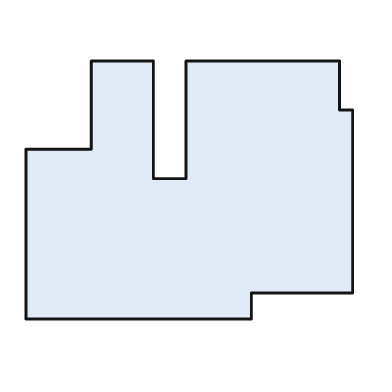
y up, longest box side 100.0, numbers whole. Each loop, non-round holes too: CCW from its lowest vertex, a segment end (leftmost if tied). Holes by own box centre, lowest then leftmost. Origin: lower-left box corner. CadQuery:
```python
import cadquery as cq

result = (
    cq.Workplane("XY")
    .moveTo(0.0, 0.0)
    .lineTo(69.0, 0.0)
    .lineTo(69.0, 8.0)
    .lineTo(100.0, 8.0)
    .lineTo(100.0, 64.0)
    .lineTo(96.0, 64.0)
    .lineTo(96.0, 79.0)
    .lineTo(49.0, 79.0)
    .lineTo(49.0, 43.0)
    .lineTo(39.0, 43.0)
    .lineTo(39.0, 79.0)
    .lineTo(20.0, 79.0)
    .lineTo(20.0, 52.0)
    .lineTo(0.0, 52.0)
    .close()
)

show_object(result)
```